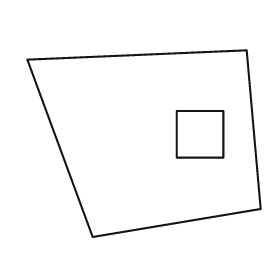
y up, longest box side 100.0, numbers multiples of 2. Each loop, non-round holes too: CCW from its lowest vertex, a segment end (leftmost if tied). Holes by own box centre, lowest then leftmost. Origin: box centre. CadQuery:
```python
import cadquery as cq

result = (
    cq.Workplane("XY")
    .moveTo(-22.0, -40.0)
    .lineTo(50.0, -28.0)
    .lineTo(44.0, 40.0)
    .lineTo(-50.0, 36.0)
    .close()
    .moveTo(14.0, -6.0)
    .lineTo(34.0, -6.0)
    .lineTo(34.0, 14.0)
    .lineTo(14.0, 14.0)
    .close()
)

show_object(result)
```